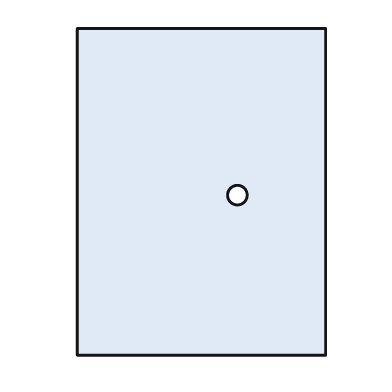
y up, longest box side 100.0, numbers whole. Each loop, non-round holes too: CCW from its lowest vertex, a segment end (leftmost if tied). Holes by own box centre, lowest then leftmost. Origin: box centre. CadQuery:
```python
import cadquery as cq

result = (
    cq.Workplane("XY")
    .moveTo(-38.0, -50.0)
    .lineTo(38.0, -50.0)
    .lineTo(38.0, 50.0)
    .lineTo(-38.0, 50.0)
    .close()
    .moveTo(11.0, -1.0)
    .circle(3.0)
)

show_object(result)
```